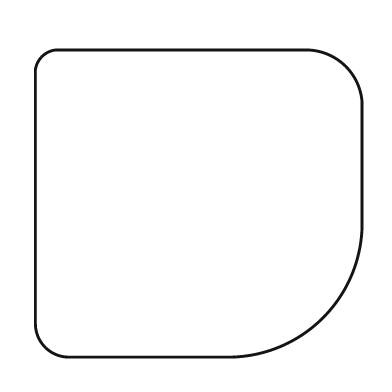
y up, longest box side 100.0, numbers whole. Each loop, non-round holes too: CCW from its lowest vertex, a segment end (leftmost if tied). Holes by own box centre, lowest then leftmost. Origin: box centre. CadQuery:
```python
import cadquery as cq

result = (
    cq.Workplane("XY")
    .moveTo(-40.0, -47.0)
    .lineTo(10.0, -47.0)
    .threePointArc((38.0, -35.0), (50.0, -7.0))
    .lineTo(50.0, 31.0)
    .threePointArc((45.0, 42.0), (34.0, 47.0))
    .lineTo(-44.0, 47.0)
    .threePointArc((-48.0, 45.0), (-50.0, 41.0))
    .lineTo(-50.0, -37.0)
    .threePointArc((-47.0, -44.0), (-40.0, -47.0))
    .close()
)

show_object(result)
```